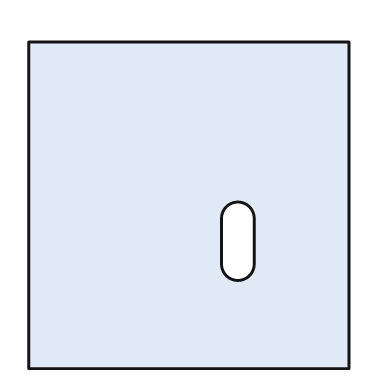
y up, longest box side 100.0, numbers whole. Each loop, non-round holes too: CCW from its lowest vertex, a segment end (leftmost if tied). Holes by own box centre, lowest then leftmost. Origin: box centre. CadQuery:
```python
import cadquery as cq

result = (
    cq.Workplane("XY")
    .moveTo(-49.0, -50.0)
    .lineTo(49.0, -50.0)
    .lineTo(49.0, 50.0)
    .lineTo(-49.0, 50.0)
    .close()
    .moveTo(10.0, -18.0)
    .threePointArc((15.0, -23.0), (20.0, -18.0))
    .lineTo(20.0, -4.0)
    .threePointArc((15.0, 1.0), (10.0, -4.0))
    .close()
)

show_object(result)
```